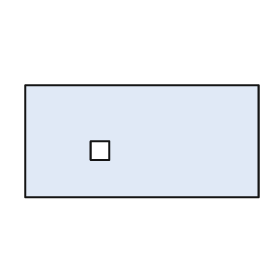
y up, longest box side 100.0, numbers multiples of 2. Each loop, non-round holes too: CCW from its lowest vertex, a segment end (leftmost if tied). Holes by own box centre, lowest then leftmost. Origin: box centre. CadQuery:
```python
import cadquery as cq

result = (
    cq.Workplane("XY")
    .moveTo(-50.0, -24.0)
    .lineTo(50.0, -24.0)
    .lineTo(50.0, 24.0)
    .lineTo(-50.0, 24.0)
    .close()
    .moveTo(-22.0, -8.0)
    .lineTo(-14.0, -8.0)
    .lineTo(-14.0, 0.0)
    .lineTo(-22.0, 0.0)
    .close()
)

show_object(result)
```